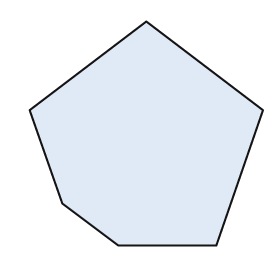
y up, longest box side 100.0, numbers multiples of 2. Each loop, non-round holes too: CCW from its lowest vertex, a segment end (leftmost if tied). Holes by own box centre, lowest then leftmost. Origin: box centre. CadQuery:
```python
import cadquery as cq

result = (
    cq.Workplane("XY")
    .moveTo(-12.0, -48.0)
    .lineTo(30.0, -48.0)
    .lineTo(50.0, 10.0)
    .lineTo(0.0, 48.0)
    .lineTo(-50.0, 10.0)
    .lineTo(-36.0, -30.0)
    .close()
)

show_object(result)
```